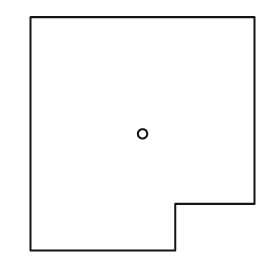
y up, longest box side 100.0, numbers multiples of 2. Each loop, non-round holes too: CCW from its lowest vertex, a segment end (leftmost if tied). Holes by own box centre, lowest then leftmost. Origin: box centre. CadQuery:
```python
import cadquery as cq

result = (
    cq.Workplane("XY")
    .moveTo(-48.0, -50.0)
    .lineTo(14.0, -50.0)
    .lineTo(14.0, -30.0)
    .lineTo(48.0, -30.0)
    .lineTo(48.0, 50.0)
    .lineTo(-48.0, 50.0)
    .close()
    .moveTo(0.0, 0.0)
    .circle(2.0)
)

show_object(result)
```